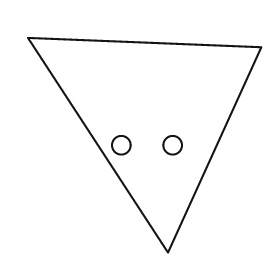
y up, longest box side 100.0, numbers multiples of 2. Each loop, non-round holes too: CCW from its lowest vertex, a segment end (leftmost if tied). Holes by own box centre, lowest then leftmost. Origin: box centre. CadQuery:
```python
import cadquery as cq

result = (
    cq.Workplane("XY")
    .moveTo(10.0, -46.0)
    .lineTo(50.0, 42.0)
    .lineTo(-50.0, 46.0)
    .close()
    .moveTo(-10.0, 0.0)
    .circle(4.0)
    .moveTo(12.0, 0.0)
    .circle(4.0)
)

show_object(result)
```